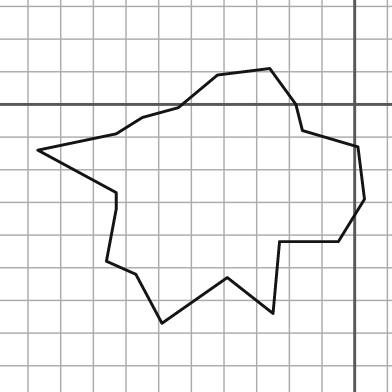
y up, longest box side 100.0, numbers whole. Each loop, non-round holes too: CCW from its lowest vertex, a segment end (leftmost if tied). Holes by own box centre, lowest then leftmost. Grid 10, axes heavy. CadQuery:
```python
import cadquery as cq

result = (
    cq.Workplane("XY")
    .moveTo(-59.0, -67.0)
    .lineTo(-39.0, -53.0)
    .lineTo(-25.0, -64.0)
    .lineTo(-23.0, -42.0)
    .lineTo(-5.0, -42.0)
    .lineTo(3.0, -29.0)
    .lineTo(1.0, -13.0)
    .lineTo(-16.0, -8.0)
    .lineTo(-18.0, 0.0)
    .lineTo(-26.0, 11.0)
    .lineTo(-42.0, 9.0)
    .lineTo(-54.0, -1.0)
    .lineTo(-65.0, -4.0)
    .lineTo(-73.0, -9.0)
    .lineTo(-97.0, -14.0)
    .lineTo(-73.0, -27.0)
    .lineTo(-73.0, -32.0)
    .lineTo(-76.0, -48.0)
    .lineTo(-67.0, -52.0)
    .close()
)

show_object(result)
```